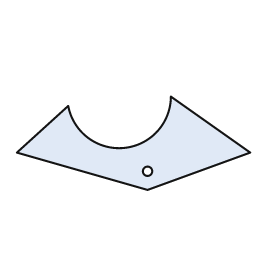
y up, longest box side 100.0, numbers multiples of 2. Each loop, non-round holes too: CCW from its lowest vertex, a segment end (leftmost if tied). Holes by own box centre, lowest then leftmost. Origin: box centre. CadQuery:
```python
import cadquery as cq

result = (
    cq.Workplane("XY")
    .moveTo(6.0, -20.0)
    .lineTo(50.0, -4.0)
    .lineTo(16.0, 20.0)
    .threePointArc((-4.0, -2.0), (-28.0, 16.0))
    .lineTo(-50.0, -4.0)
    .close()
    .moveTo(6.0, -12.0)
    .circle(2.0)
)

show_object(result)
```